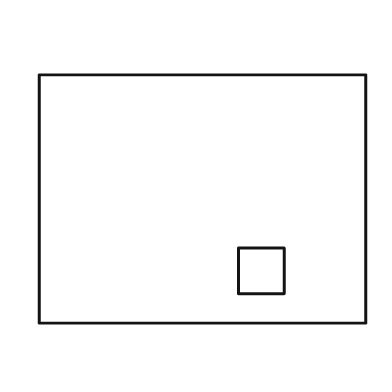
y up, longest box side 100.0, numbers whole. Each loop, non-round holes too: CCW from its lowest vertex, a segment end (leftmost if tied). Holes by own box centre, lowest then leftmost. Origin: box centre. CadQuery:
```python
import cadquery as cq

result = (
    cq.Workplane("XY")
    .moveTo(-50.0, -38.0)
    .lineTo(50.0, -38.0)
    .lineTo(50.0, 38.0)
    .lineTo(-50.0, 38.0)
    .close()
    .moveTo(11.0, -29.0)
    .lineTo(25.0, -29.0)
    .lineTo(25.0, -15.0)
    .lineTo(11.0, -15.0)
    .close()
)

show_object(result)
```